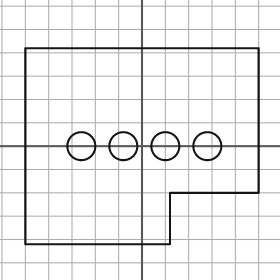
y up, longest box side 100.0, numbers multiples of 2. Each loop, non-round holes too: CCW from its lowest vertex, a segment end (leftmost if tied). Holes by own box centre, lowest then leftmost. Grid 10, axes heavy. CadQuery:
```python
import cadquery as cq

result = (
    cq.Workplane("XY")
    .moveTo(-50.0, -42.0)
    .lineTo(12.0, -42.0)
    .lineTo(12.0, -20.0)
    .lineTo(50.0, -20.0)
    .lineTo(50.0, 42.0)
    .lineTo(-50.0, 42.0)
    .close()
    .moveTo(-26.0, 0.0)
    .circle(6.0)
    .moveTo(-8.0, 0.0)
    .circle(6.0)
    .moveTo(10.0, 0.0)
    .circle(6.0)
    .moveTo(28.0, 0.0)
    .circle(6.0)
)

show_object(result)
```